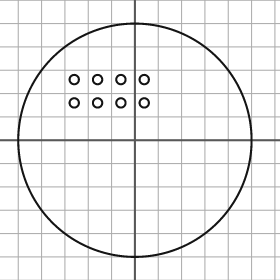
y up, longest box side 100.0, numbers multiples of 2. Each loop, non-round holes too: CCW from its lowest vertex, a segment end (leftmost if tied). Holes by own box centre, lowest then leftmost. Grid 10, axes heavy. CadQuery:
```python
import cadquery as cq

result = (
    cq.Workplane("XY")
    .moveTo(0.0, 0.0)
    .circle(50.0)
    .moveTo(-26.0, 16.0)
    .circle(2.0)
    .moveTo(-16.0, 16.0)
    .circle(2.0)
    .moveTo(-6.0, 16.0)
    .circle(2.0)
    .moveTo(4.0, 16.0)
    .circle(2.0)
    .moveTo(-26.0, 26.0)
    .circle(2.0)
    .moveTo(-16.0, 26.0)
    .circle(2.0)
    .moveTo(-6.0, 26.0)
    .circle(2.0)
    .moveTo(4.0, 26.0)
    .circle(2.0)
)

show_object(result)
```